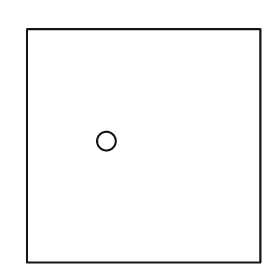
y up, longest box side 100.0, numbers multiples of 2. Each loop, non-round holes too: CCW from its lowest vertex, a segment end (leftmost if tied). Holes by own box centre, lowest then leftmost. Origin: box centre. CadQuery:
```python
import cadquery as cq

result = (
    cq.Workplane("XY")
    .moveTo(-50.0, -50.0)
    .lineTo(50.0, -50.0)
    .lineTo(50.0, 50.0)
    .lineTo(-50.0, 50.0)
    .close()
    .moveTo(-16.0, 2.0)
    .circle(4.0)
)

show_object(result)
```